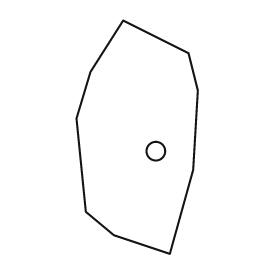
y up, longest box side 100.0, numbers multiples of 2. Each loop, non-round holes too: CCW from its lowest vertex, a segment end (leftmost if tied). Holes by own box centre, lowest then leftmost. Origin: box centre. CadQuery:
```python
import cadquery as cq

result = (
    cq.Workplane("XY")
    .moveTo(14.0, -50.0)
    .lineTo(24.0, -14.0)
    .lineTo(26.0, 20.0)
    .lineTo(22.0, 36.0)
    .lineTo(-6.0, 50.0)
    .lineTo(-20.0, 28.0)
    .lineTo(-26.0, 8.0)
    .lineTo(-22.0, -32.0)
    .lineTo(-10.0, -42.0)
    .close()
    .moveTo(8.0, -6.0)
    .circle(4.0)
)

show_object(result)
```